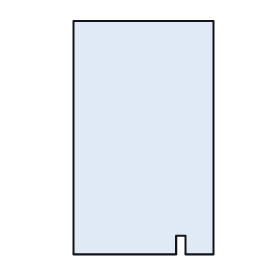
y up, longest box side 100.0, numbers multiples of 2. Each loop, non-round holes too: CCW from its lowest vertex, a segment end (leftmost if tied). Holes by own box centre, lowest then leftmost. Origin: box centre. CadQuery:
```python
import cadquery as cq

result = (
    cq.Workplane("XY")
    .moveTo(-30.0, -50.0)
    .lineTo(14.0, -50.0)
    .lineTo(14.0, -42.0)
    .lineTo(18.0, -42.0)
    .lineTo(18.0, -50.0)
    .lineTo(30.0, -50.0)
    .lineTo(30.0, 50.0)
    .lineTo(-30.0, 50.0)
    .close()
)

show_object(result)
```